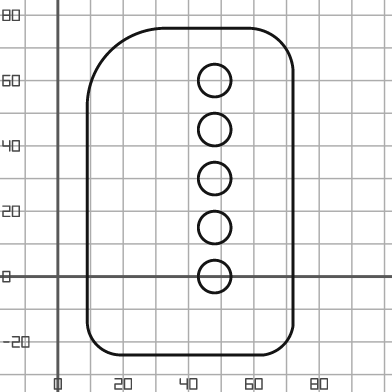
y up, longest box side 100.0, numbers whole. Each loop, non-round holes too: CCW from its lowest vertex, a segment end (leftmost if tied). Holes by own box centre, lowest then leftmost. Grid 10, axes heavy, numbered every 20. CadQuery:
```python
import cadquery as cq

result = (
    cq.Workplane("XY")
    .moveTo(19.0, -24.0)
    .lineTo(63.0, -24.0)
    .threePointArc((69.0, -21.0), (72.0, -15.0))
    .lineTo(72.0, 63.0)
    .threePointArc((68.0, 72.0), (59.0, 76.0))
    .lineTo(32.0, 76.0)
    .threePointArc((16.0, 69.0), (9.0, 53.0))
    .lineTo(9.0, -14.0)
    .threePointArc((12.0, -21.0), (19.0, -24.0))
    .close()
    .moveTo(48.0, 0.0)
    .circle(5.0)
    .moveTo(48.0, 15.0)
    .circle(5.0)
    .moveTo(48.0, 30.0)
    .circle(5.0)
    .moveTo(48.0, 45.0)
    .circle(5.0)
    .moveTo(48.0, 60.0)
    .circle(5.0)
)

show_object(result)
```